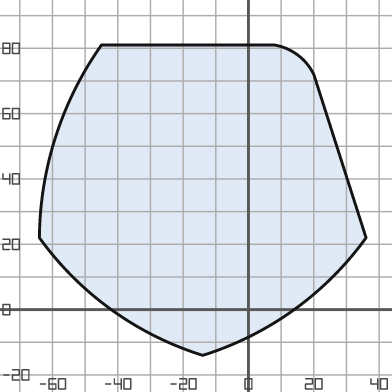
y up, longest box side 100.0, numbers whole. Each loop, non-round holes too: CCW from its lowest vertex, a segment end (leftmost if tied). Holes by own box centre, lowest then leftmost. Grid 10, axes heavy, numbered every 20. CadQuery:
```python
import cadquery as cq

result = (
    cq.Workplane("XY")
    .moveTo(-14.0, -14.0)
    .threePointArc((14.0, 0.0), (36.0, 22.0))
    .lineTo(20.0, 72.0)
    .threePointArc((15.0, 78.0), (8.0, 81.0))
    .lineTo(-45.0, 81.0)
    .threePointArc((-59.0, 53.0), (-64.0, 22.0))
    .threePointArc((-42.0, 0.0), (-14.0, -14.0))
    .close()
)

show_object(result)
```